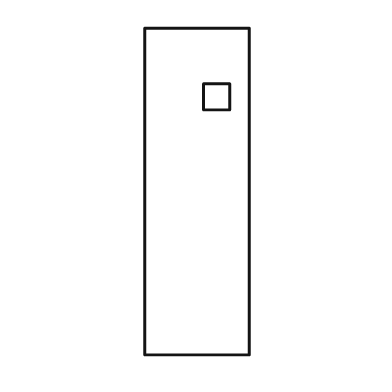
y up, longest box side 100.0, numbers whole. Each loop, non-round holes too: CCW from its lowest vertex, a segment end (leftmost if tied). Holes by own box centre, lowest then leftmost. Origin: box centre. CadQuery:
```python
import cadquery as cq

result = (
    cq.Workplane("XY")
    .moveTo(-16.0, -50.0)
    .lineTo(16.0, -50.0)
    .lineTo(16.0, 50.0)
    .lineTo(-16.0, 50.0)
    .close()
    .moveTo(2.0, 25.0)
    .lineTo(10.0, 25.0)
    .lineTo(10.0, 33.0)
    .lineTo(2.0, 33.0)
    .close()
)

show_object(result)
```